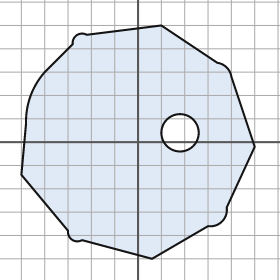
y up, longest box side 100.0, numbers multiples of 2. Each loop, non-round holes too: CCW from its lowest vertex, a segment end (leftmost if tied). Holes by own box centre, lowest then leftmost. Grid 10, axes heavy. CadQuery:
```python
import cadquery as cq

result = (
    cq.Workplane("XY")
    .moveTo(6.0, -50.0)
    .lineTo(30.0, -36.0)
    .threePointArc((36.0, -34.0), (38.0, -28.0))
    .lineTo(50.0, -2.0)
    .lineTo(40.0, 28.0)
    .threePointArc((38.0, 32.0), (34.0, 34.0))
    .lineTo(10.0, 50.0)
    .lineTo(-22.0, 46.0)
    .threePointArc((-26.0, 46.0), (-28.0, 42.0))
    .lineTo(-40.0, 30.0)
    .threePointArc((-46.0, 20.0), (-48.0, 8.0))
    .lineTo(-50.0, -14.0)
    .lineTo(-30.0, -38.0)
    .threePointArc((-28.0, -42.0), (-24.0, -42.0))
    .close()
    .moveTo(18.0, 4.0)
    .circle(8.0)
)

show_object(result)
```